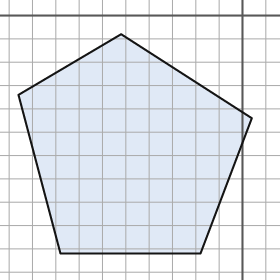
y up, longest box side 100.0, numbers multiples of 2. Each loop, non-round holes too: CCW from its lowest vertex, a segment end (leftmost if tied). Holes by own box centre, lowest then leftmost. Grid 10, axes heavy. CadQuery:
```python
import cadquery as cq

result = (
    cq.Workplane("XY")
    .moveTo(-78.0, -102.0)
    .lineTo(-18.0, -102.0)
    .lineTo(4.0, -44.0)
    .lineTo(-52.0, -8.0)
    .lineTo(-96.0, -34.0)
    .close()
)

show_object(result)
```